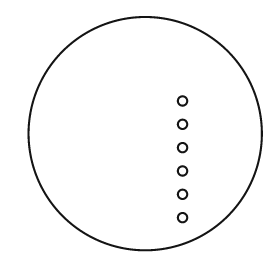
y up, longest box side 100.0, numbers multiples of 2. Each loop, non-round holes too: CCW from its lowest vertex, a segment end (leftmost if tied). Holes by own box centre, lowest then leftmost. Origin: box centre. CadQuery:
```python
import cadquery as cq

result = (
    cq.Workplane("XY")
    .moveTo(0.0, 0.0)
    .circle(50.0)
    .moveTo(16.0, -36.0)
    .circle(2.0)
    .moveTo(16.0, -26.0)
    .circle(2.0)
    .moveTo(16.0, -16.0)
    .circle(2.0)
    .moveTo(16.0, -6.0)
    .circle(2.0)
    .moveTo(16.0, 4.0)
    .circle(2.0)
    .moveTo(16.0, 14.0)
    .circle(2.0)
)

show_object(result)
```